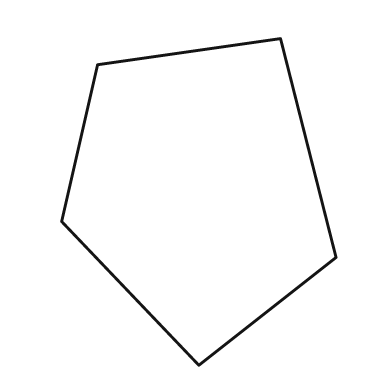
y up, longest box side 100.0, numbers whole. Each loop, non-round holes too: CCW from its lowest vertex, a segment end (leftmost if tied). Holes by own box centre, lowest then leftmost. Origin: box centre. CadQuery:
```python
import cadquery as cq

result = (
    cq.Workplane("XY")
    .moveTo(0.0, -50.0)
    .lineTo(42.0, -17.0)
    .lineTo(25.0, 50.0)
    .lineTo(-31.0, 42.0)
    .lineTo(-42.0, -6.0)
    .close()
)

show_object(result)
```